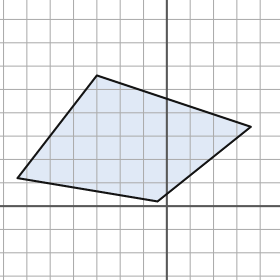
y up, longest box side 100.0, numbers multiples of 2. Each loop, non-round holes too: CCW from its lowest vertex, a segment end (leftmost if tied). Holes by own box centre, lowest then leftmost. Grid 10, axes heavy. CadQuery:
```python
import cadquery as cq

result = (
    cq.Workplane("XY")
    .moveTo(-4.0, 2.0)
    .lineTo(36.0, 34.0)
    .lineTo(-30.0, 56.0)
    .lineTo(-64.0, 12.0)
    .close()
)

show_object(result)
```